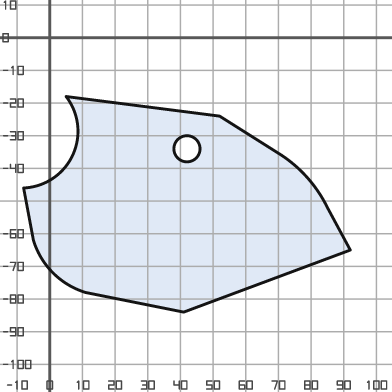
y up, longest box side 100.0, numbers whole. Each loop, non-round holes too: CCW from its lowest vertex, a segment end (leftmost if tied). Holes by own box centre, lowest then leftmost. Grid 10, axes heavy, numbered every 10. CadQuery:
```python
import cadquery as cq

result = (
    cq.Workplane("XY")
    .moveTo(41.0, -84.0)
    .lineTo(92.0, -65.0)
    .lineTo(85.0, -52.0)
    .threePointArc((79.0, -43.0), (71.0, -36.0))
    .lineTo(52.0, -24.0)
    .lineTo(5.0, -18.0)
    .threePointArc((7.0, -36.0), (-8.0, -46.0))
    .lineTo(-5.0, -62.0)
    .threePointArc((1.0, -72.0), (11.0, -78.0))
    .close()
    .moveTo(42.0, -34.0)
    .circle(4.0)
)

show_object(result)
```